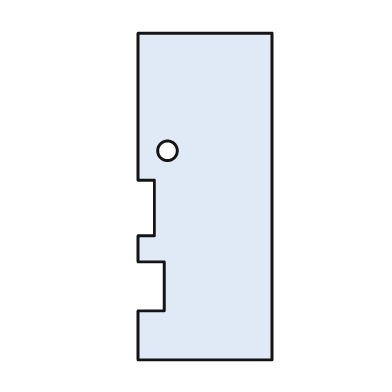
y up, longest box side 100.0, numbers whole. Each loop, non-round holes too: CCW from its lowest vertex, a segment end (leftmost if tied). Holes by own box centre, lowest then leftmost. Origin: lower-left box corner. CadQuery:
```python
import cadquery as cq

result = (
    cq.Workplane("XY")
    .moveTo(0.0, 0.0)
    .lineTo(41.0, 0.0)
    .lineTo(41.0, 100.0)
    .lineTo(0.0, 100.0)
    .lineTo(0.0, 55.0)
    .lineTo(5.0, 55.0)
    .lineTo(5.0, 38.0)
    .lineTo(0.0, 38.0)
    .lineTo(0.0, 30.0)
    .lineTo(8.0, 30.0)
    .lineTo(8.0, 15.0)
    .lineTo(0.0, 15.0)
    .close()
    .moveTo(9.0, 64.0)
    .circle(3.0)
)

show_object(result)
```